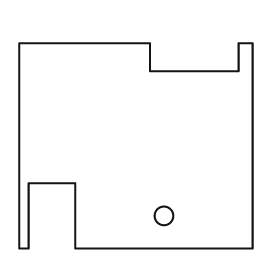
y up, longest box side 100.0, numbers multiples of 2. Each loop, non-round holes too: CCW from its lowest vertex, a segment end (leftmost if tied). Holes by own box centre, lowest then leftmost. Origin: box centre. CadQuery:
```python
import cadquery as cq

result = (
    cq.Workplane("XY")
    .moveTo(-50.0, -44.0)
    .lineTo(-46.0, -44.0)
    .lineTo(-46.0, -16.0)
    .lineTo(-26.0, -16.0)
    .lineTo(-26.0, -44.0)
    .lineTo(50.0, -44.0)
    .lineTo(50.0, 44.0)
    .lineTo(44.0, 44.0)
    .lineTo(44.0, 32.0)
    .lineTo(6.0, 32.0)
    .lineTo(6.0, 44.0)
    .lineTo(-50.0, 44.0)
    .close()
    .moveTo(12.0, -30.0)
    .circle(4.0)
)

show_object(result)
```